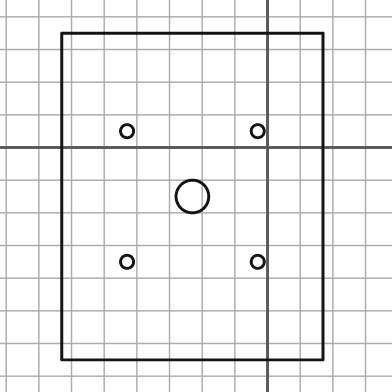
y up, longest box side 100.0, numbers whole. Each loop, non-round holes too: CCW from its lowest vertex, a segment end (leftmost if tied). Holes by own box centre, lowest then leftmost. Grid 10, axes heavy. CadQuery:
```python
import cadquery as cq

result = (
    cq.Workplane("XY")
    .moveTo(-63.0, -65.0)
    .lineTo(17.0, -65.0)
    .lineTo(17.0, 35.0)
    .lineTo(-63.0, 35.0)
    .close()
    .moveTo(-43.0, -35.0)
    .circle(2.0)
    .moveTo(-3.0, -35.0)
    .circle(2.0)
    .moveTo(-23.0, -15.0)
    .circle(5.0)
    .moveTo(-43.0, 5.0)
    .circle(2.0)
    .moveTo(-3.0, 5.0)
    .circle(2.0)
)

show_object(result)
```